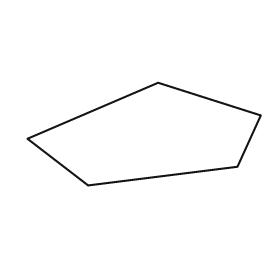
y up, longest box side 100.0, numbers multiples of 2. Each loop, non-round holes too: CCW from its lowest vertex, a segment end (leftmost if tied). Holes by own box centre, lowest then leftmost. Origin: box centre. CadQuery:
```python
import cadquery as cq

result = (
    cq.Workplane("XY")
    .moveTo(-24.0, -22.0)
    .lineTo(40.0, -14.0)
    .lineTo(50.0, 8.0)
    .lineTo(6.0, 22.0)
    .lineTo(-50.0, -2.0)
    .close()
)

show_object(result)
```